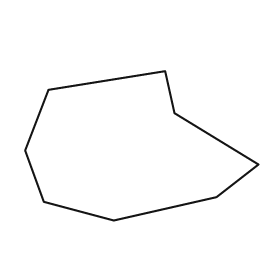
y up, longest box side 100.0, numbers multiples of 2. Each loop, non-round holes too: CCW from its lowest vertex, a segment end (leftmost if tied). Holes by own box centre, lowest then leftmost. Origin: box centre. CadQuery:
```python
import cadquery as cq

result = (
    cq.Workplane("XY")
    .moveTo(-12.0, -32.0)
    .lineTo(32.0, -22.0)
    .lineTo(50.0, -8.0)
    .lineTo(14.0, 14.0)
    .lineTo(10.0, 32.0)
    .lineTo(-40.0, 24.0)
    .lineTo(-50.0, -2.0)
    .lineTo(-42.0, -24.0)
    .close()
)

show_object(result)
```